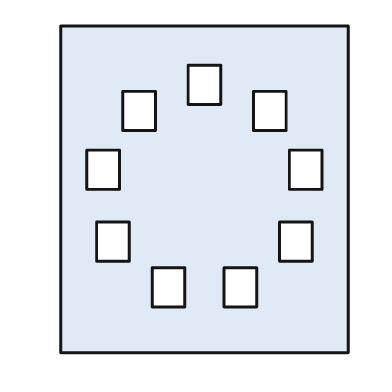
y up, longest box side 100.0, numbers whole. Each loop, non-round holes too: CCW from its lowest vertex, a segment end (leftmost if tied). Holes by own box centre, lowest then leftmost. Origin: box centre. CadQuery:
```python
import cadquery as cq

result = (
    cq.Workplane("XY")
    .moveTo(-44.0, -50.0)
    .lineTo(44.0, -50.0)
    .lineTo(44.0, 50.0)
    .lineTo(-44.0, 50.0)
    .close()
    .moveTo(-16.0, -36.0)
    .lineTo(-6.0, -36.0)
    .lineTo(-6.0, -24.0)
    .lineTo(-16.0, -24.0)
    .close()
    .moveTo(6.0, -36.0)
    .lineTo(16.0, -36.0)
    .lineTo(16.0, -24.0)
    .lineTo(6.0, -24.0)
    .close()
    .moveTo(-33.0, -22.0)
    .lineTo(-23.0, -22.0)
    .lineTo(-23.0, -10.0)
    .lineTo(-33.0, -10.0)
    .close()
    .moveTo(23.0, -22.0)
    .lineTo(33.0, -22.0)
    .lineTo(33.0, -10.0)
    .lineTo(23.0, -10.0)
    .close()
    .moveTo(-36.0, 0.0)
    .lineTo(-26.0, 0.0)
    .lineTo(-26.0, 12.0)
    .lineTo(-36.0, 12.0)
    .close()
    .moveTo(26.0, 0.0)
    .lineTo(36.0, 0.0)
    .lineTo(36.0, 12.0)
    .lineTo(26.0, 12.0)
    .close()
    .moveTo(-25.0, 18.0)
    .lineTo(-15.0, 18.0)
    .lineTo(-15.0, 30.0)
    .lineTo(-25.0, 30.0)
    .close()
    .moveTo(15.0, 18.0)
    .lineTo(25.0, 18.0)
    .lineTo(25.0, 30.0)
    .lineTo(15.0, 30.0)
    .close()
    .moveTo(-5.0, 26.0)
    .lineTo(5.0, 26.0)
    .lineTo(5.0, 38.0)
    .lineTo(-5.0, 38.0)
    .close()
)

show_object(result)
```